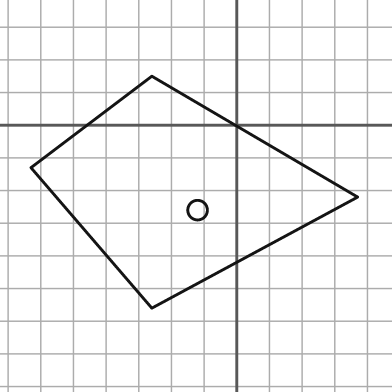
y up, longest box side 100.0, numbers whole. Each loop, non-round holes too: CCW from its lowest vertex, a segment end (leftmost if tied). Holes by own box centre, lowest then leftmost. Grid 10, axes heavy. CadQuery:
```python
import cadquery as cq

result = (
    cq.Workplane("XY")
    .moveTo(-26.0, -56.0)
    .lineTo(37.0, -22.0)
    .lineTo(-26.0, 15.0)
    .lineTo(-63.0, -13.0)
    .close()
    .moveTo(-12.0, -26.0)
    .circle(3.0)
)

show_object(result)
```